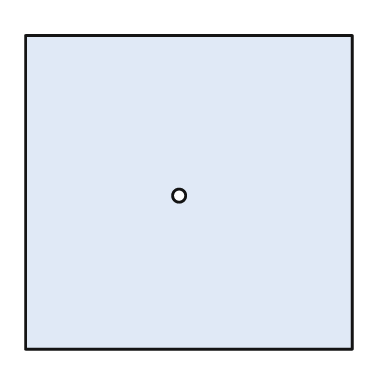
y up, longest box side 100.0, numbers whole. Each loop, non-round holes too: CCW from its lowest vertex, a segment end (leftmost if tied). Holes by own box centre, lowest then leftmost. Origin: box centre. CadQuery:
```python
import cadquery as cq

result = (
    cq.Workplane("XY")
    .moveTo(-50.0, -48.0)
    .lineTo(50.0, -48.0)
    .lineTo(50.0, 48.0)
    .lineTo(-50.0, 48.0)
    .close()
    .moveTo(-3.0, -1.0)
    .circle(2.0)
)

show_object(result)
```